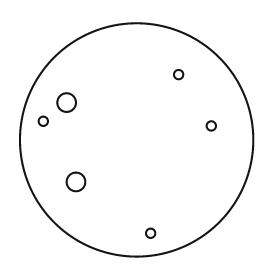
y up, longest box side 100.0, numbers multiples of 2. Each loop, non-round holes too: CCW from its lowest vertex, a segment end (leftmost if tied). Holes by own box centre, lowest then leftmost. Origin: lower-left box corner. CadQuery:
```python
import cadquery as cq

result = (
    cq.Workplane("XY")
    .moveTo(50.0, 50.0)
    .circle(50.0)
    .moveTo(56.0, 10.0)
    .circle(2.0)
    .moveTo(24.0, 32.0)
    .circle(4.0)
    .moveTo(82.0, 56.0)
    .circle(2.0)
    .moveTo(10.0, 58.0)
    .circle(2.0)
    .moveTo(20.0, 66.0)
    .circle(4.0)
    .moveTo(68.0, 78.0)
    .circle(2.0)
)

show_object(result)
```